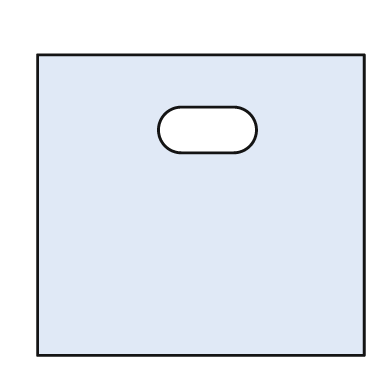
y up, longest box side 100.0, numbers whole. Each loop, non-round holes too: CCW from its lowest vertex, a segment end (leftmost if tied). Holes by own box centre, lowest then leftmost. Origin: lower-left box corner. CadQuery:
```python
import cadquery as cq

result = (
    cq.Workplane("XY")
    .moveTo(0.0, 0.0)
    .lineTo(100.0, 0.0)
    .lineTo(100.0, 92.0)
    .lineTo(0.0, 92.0)
    .close()
    .moveTo(44.0, 62.0)
    .lineTo(60.0, 62.0)
    .threePointArc((67.0, 69.0), (60.0, 76.0))
    .lineTo(44.0, 76.0)
    .threePointArc((37.0, 69.0), (44.0, 62.0))
    .close()
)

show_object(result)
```